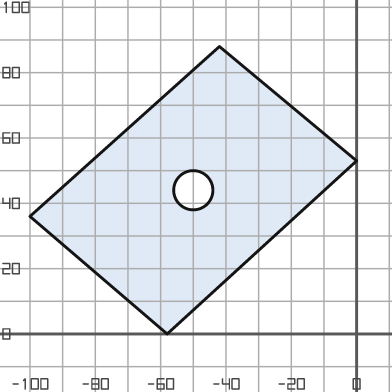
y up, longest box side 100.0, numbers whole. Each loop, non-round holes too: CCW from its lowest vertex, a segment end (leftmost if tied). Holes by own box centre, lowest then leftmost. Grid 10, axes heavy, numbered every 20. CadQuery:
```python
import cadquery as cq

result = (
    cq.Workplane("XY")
    .moveTo(-58.0, 0.0)
    .lineTo(0.0, 53.0)
    .lineTo(-42.0, 88.0)
    .lineTo(-100.0, 36.0)
    .close()
    .moveTo(-50.0, 44.0)
    .circle(6.0)
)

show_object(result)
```